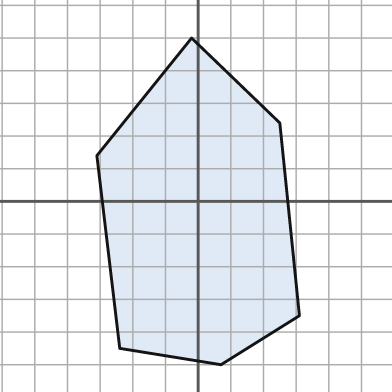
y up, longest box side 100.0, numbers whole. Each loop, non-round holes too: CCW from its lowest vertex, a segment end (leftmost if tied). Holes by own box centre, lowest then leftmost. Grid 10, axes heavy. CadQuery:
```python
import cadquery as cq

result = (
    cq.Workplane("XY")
    .moveTo(7.0, -50.0)
    .lineTo(31.0, -35.0)
    .lineTo(25.0, 24.0)
    .lineTo(-2.0, 50.0)
    .lineTo(-31.0, 14.0)
    .lineTo(-24.0, -45.0)
    .close()
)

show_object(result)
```